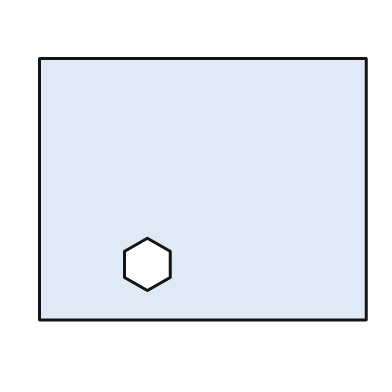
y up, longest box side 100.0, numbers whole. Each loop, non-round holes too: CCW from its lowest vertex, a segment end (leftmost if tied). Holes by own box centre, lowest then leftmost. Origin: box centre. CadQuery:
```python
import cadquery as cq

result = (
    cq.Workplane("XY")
    .moveTo(-50.0, -40.0)
    .lineTo(50.0, -40.0)
    .lineTo(50.0, 40.0)
    .lineTo(-50.0, 40.0)
    .close()
    .moveTo(-17.0, -31.0)
    .lineTo(-10.0, -27.0)
    .lineTo(-10.0, -19.0)
    .lineTo(-17.0, -15.0)
    .lineTo(-24.0, -19.0)
    .lineTo(-24.0, -27.0)
    .close()
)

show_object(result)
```